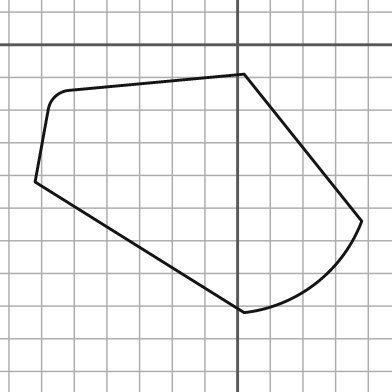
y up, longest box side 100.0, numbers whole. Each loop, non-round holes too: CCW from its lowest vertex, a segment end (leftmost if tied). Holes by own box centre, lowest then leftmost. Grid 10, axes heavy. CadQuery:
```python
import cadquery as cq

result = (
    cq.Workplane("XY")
    .moveTo(2.0, -82.0)
    .threePointArc((24.0, -73.0), (38.0, -54.0))
    .lineTo(2.0, -9.0)
    .lineTo(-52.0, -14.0)
    .threePointArc((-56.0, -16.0), (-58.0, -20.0))
    .lineTo(-62.0, -42.0)
    .close()
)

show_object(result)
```